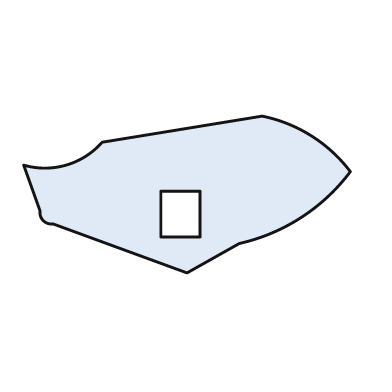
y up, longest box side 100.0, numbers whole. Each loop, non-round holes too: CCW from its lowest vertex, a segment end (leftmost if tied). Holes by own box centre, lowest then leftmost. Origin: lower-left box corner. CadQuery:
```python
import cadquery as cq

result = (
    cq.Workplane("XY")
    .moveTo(50.0, 0.0)
    .lineTo(66.0, 9.0)
    .threePointArc((85.0, 17.0), (100.0, 31.0))
    .threePointArc((88.0, 42.0), (73.0, 48.0))
    .lineTo(24.0, 40.0)
    .threePointArc((13.0, 33.0), (0.0, 33.0))
    .lineTo(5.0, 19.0)
    .threePointArc((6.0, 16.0), (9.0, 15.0))
    .close()
    .moveTo(42.0, 11.0)
    .lineTo(54.0, 11.0)
    .lineTo(54.0, 25.0)
    .lineTo(42.0, 25.0)
    .close()
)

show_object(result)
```